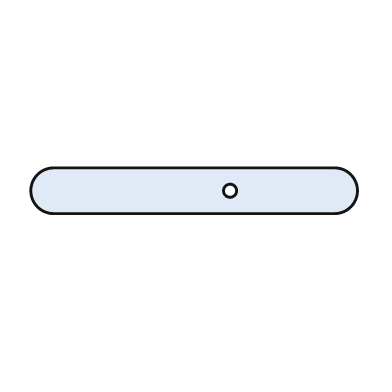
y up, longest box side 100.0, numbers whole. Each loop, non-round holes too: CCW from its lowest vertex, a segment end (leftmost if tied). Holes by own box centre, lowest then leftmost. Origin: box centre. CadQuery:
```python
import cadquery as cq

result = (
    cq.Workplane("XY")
    .moveTo(-43.0, -7.0)
    .lineTo(43.0, -7.0)
    .threePointArc((50.0, 0.0), (43.0, 7.0))
    .lineTo(-43.0, 7.0)
    .threePointArc((-50.0, 0.0), (-43.0, -7.0))
    .close()
    .moveTo(11.0, 0.0)
    .circle(2.0)
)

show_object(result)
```